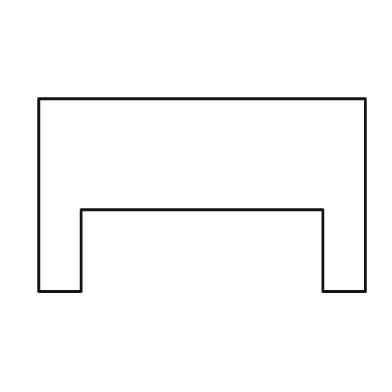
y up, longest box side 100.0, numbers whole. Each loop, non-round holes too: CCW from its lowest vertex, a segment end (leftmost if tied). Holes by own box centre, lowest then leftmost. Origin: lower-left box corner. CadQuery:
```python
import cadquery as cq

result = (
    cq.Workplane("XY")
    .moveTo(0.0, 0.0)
    .lineTo(13.0, 0.0)
    .lineTo(13.0, 25.0)
    .lineTo(87.0, 25.0)
    .lineTo(87.0, 0.0)
    .lineTo(100.0, 0.0)
    .lineTo(100.0, 59.0)
    .lineTo(0.0, 59.0)
    .close()
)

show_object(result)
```